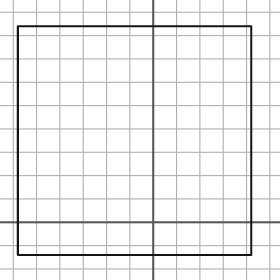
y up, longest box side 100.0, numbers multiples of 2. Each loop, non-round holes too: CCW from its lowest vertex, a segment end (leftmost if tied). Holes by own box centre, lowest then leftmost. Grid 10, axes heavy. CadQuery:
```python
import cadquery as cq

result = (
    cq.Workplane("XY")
    .moveTo(-58.0, -14.0)
    .lineTo(42.0, -14.0)
    .lineTo(42.0, 84.0)
    .lineTo(-58.0, 84.0)
    .close()
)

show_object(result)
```